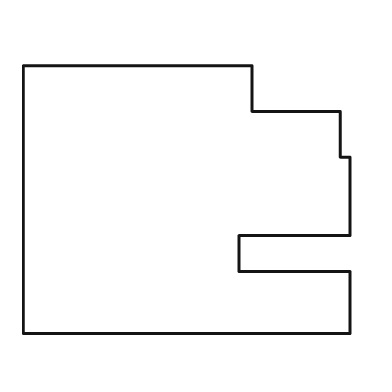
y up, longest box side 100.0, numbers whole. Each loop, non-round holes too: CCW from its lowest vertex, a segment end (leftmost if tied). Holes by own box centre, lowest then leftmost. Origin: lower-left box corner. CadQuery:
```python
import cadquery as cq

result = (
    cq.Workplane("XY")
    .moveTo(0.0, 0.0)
    .lineTo(100.0, 0.0)
    .lineTo(100.0, 19.0)
    .lineTo(66.0, 19.0)
    .lineTo(66.0, 30.0)
    .lineTo(100.0, 30.0)
    .lineTo(100.0, 54.0)
    .lineTo(97.0, 54.0)
    .lineTo(97.0, 68.0)
    .lineTo(70.0, 68.0)
    .lineTo(70.0, 82.0)
    .lineTo(0.0, 82.0)
    .close()
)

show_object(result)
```